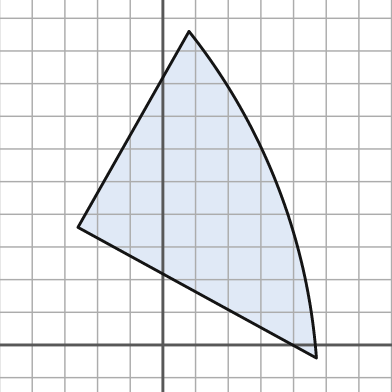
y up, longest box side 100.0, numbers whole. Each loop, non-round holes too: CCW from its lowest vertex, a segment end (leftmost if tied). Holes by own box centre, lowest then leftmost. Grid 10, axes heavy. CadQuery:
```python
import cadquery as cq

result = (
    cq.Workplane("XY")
    .moveTo(47.0, -4.0)
    .threePointArc((35.0, 49.0), (8.0, 96.0))
    .lineTo(-26.0, 36.0)
    .close()
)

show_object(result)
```